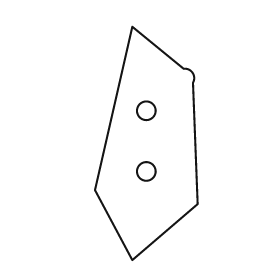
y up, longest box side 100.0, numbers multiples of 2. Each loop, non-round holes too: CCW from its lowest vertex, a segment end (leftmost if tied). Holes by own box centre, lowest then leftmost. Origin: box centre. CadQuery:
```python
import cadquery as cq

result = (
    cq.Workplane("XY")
    .moveTo(-6.0, -50.0)
    .lineTo(22.0, -26.0)
    .lineTo(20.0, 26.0)
    .threePointArc((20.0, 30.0), (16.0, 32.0))
    .lineTo(-6.0, 50.0)
    .lineTo(-22.0, -20.0)
    .close()
    .moveTo(0.0, -12.0)
    .circle(4.0)
    .moveTo(0.0, 14.0)
    .circle(4.0)
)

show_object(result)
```